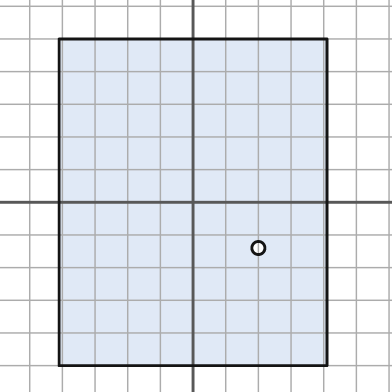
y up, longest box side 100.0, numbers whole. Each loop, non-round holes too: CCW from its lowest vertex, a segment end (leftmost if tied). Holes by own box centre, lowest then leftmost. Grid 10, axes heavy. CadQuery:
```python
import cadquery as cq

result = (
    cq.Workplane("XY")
    .moveTo(-41.0, -50.0)
    .lineTo(41.0, -50.0)
    .lineTo(41.0, 50.0)
    .lineTo(-41.0, 50.0)
    .close()
    .moveTo(20.0, -14.0)
    .circle(2.0)
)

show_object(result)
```